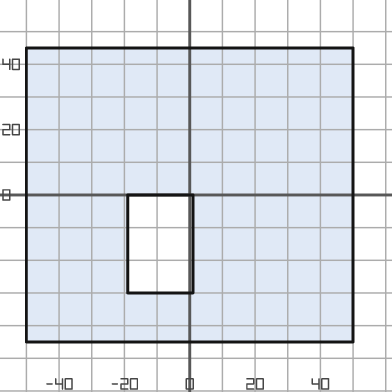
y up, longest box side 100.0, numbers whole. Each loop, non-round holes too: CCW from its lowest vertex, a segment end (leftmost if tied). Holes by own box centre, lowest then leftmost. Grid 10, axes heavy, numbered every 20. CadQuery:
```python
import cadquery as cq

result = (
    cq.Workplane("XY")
    .moveTo(-50.0, -45.0)
    .lineTo(50.0, -45.0)
    .lineTo(50.0, 45.0)
    .lineTo(-50.0, 45.0)
    .close()
    .moveTo(-19.0, -30.0)
    .lineTo(1.0, -30.0)
    .lineTo(1.0, 0.0)
    .lineTo(-19.0, 0.0)
    .close()
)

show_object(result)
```